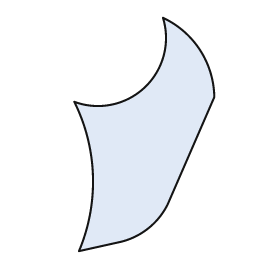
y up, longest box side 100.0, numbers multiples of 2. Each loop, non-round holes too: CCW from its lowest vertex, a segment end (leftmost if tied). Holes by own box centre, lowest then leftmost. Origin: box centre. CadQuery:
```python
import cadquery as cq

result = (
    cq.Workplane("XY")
    .moveTo(-28.0, -50.0)
    .lineTo(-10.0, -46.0)
    .threePointArc((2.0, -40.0), (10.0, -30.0))
    .lineTo(30.0, 16.0)
    .threePointArc((24.0, 36.0), (8.0, 50.0))
    .threePointArc((0.0, 20.0), (-30.0, 14.0))
    .threePointArc((-22.0, -18.0), (-28.0, -50.0))
    .close()
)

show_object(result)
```